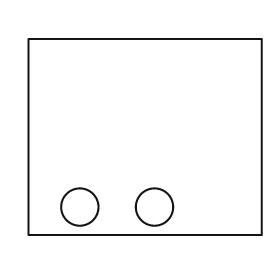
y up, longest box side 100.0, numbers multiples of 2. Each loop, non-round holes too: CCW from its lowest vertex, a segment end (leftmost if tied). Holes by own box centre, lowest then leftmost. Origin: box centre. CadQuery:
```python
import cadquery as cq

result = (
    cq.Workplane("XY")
    .moveTo(-50.0, -42.0)
    .lineTo(50.0, -42.0)
    .lineTo(50.0, 42.0)
    .lineTo(-50.0, 42.0)
    .close()
    .moveTo(-28.0, -30.0)
    .circle(8.0)
    .moveTo(4.0, -30.0)
    .circle(8.0)
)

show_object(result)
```